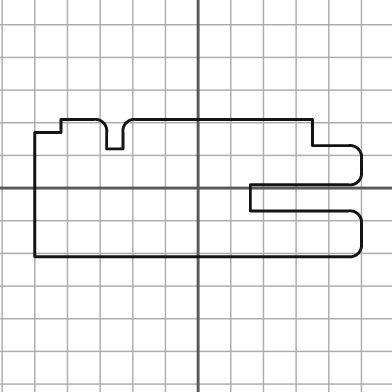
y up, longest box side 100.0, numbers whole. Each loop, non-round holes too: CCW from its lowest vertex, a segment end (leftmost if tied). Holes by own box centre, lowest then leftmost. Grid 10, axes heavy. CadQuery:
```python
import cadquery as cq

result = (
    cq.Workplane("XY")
    .moveTo(-50.0, -21.0)
    .lineTo(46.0, -21.0)
    .threePointArc((49.0, -20.0), (50.0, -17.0))
    .lineTo(50.0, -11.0)
    .threePointArc((49.0, -8.0), (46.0, -7.0))
    .lineTo(16.0, -7.0)
    .lineTo(16.0, 1.0)
    .lineTo(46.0, 1.0)
    .threePointArc((49.0, 2.0), (50.0, 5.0))
    .lineTo(50.0, 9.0)
    .threePointArc((49.0, 12.0), (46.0, 13.0))
    .lineTo(35.0, 13.0)
    .lineTo(35.0, 21.0)
    .lineTo(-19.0, 21.0)
    .threePointArc((-22.0, 20.0), (-23.0, 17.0))
    .lineTo(-23.0, 12.0)
    .lineTo(-28.0, 12.0)
    .lineTo(-28.0, 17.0)
    .threePointArc((-29.0, 20.0), (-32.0, 21.0))
    .lineTo(-42.0, 21.0)
    .lineTo(-42.0, 17.0)
    .lineTo(-50.0, 17.0)
    .close()
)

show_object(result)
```